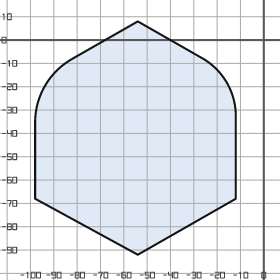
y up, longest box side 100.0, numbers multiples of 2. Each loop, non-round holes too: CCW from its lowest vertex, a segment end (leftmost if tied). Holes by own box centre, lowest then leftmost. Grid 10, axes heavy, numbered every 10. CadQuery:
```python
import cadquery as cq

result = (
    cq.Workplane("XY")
    .moveTo(-54.0, -92.0)
    .lineTo(-12.0, -68.0)
    .lineTo(-12.0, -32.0)
    .threePointArc((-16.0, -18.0), (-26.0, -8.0))
    .lineTo(-54.0, 8.0)
    .lineTo(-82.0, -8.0)
    .threePointArc((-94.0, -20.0), (-98.0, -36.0))
    .lineTo(-98.0, -68.0)
    .close()
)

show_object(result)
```